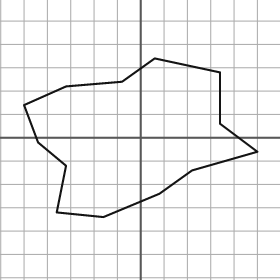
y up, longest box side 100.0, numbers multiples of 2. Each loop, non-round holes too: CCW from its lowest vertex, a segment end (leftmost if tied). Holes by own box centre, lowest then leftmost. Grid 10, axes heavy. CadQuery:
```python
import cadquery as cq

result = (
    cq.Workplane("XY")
    .moveTo(-16.0, -34.0)
    .lineTo(8.0, -24.0)
    .lineTo(22.0, -14.0)
    .lineTo(50.0, -6.0)
    .lineTo(34.0, 6.0)
    .lineTo(34.0, 28.0)
    .lineTo(6.0, 34.0)
    .lineTo(-8.0, 24.0)
    .lineTo(-32.0, 22.0)
    .lineTo(-50.0, 14.0)
    .lineTo(-44.0, -2.0)
    .lineTo(-32.0, -12.0)
    .lineTo(-36.0, -32.0)
    .close()
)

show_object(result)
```